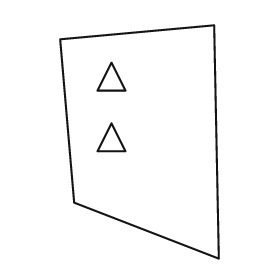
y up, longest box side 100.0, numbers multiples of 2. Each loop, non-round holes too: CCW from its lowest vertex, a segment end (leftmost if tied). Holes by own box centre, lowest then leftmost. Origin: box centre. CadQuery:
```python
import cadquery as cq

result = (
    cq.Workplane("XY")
    .moveTo(34.0, -50.0)
    .lineTo(32.0, 50.0)
    .lineTo(-34.0, 44.0)
    .lineTo(-28.0, -26.0)
    .close()
    .moveTo(-18.0, -4.0)
    .lineTo(-6.0, -4.0)
    .lineTo(-12.0, 8.0)
    .close()
    .moveTo(-18.0, 22.0)
    .lineTo(-6.0, 22.0)
    .lineTo(-12.0, 34.0)
    .close()
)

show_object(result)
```